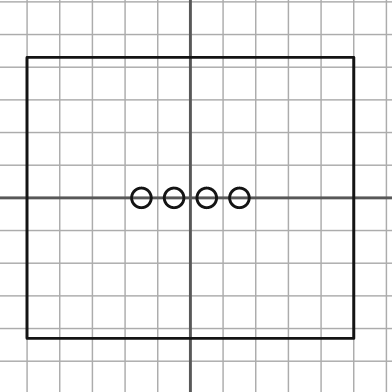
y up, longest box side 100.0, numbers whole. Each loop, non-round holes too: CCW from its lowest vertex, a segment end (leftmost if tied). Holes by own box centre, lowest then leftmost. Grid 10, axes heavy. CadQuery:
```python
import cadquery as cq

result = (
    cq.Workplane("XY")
    .moveTo(-50.0, -43.0)
    .lineTo(50.0, -43.0)
    .lineTo(50.0, 43.0)
    .lineTo(-50.0, 43.0)
    .close()
    .moveTo(-15.0, 0.0)
    .circle(3.0)
    .moveTo(-5.0, 0.0)
    .circle(3.0)
    .moveTo(5.0, 0.0)
    .circle(3.0)
    .moveTo(15.0, 0.0)
    .circle(3.0)
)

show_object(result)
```